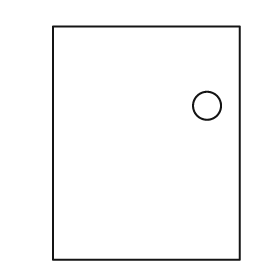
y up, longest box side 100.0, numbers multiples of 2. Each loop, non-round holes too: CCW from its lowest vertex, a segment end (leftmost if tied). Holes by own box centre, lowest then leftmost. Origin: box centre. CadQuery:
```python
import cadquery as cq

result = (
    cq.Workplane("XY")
    .moveTo(-40.0, -50.0)
    .lineTo(40.0, -50.0)
    .lineTo(40.0, 50.0)
    .lineTo(-40.0, 50.0)
    .close()
    .moveTo(26.0, 16.0)
    .circle(6.0)
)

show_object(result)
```